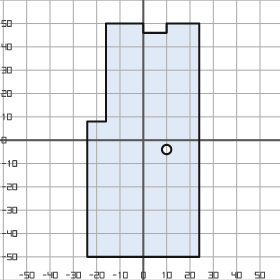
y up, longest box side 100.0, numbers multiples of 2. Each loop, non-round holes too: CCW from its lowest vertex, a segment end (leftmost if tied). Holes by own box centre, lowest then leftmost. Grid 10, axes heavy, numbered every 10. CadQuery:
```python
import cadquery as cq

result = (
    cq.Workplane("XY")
    .moveTo(-24.0, -50.0)
    .lineTo(24.0, -50.0)
    .lineTo(24.0, 50.0)
    .lineTo(10.0, 50.0)
    .lineTo(10.0, 46.0)
    .lineTo(0.0, 46.0)
    .lineTo(0.0, 50.0)
    .lineTo(-16.0, 50.0)
    .lineTo(-16.0, 8.0)
    .lineTo(-24.0, 8.0)
    .close()
    .moveTo(10.0, -4.0)
    .circle(2.0)
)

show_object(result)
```